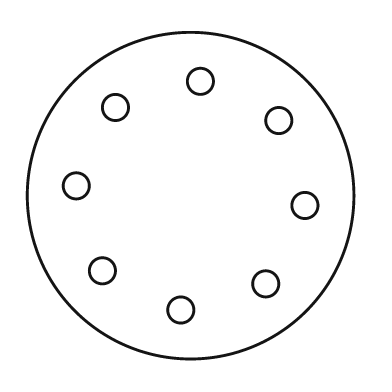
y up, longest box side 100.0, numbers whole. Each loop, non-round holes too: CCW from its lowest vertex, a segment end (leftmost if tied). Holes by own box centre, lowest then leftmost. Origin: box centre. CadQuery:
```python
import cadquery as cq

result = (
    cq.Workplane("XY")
    .moveTo(0.0, 0.0)
    .circle(50.0)
    .moveTo(-3.0, -35.0)
    .circle(4.0)
    .moveTo(23.0, -27.0)
    .circle(4.0)
    .moveTo(-27.0, -23.0)
    .circle(4.0)
    .moveTo(35.0, -3.0)
    .circle(4.0)
    .moveTo(-35.0, 3.0)
    .circle(4.0)
    .moveTo(27.0, 23.0)
    .circle(4.0)
    .moveTo(-23.0, 27.0)
    .circle(4.0)
    .moveTo(3.0, 35.0)
    .circle(4.0)
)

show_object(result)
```